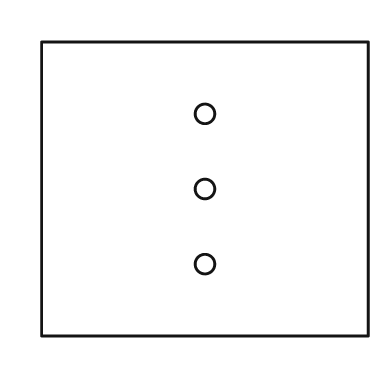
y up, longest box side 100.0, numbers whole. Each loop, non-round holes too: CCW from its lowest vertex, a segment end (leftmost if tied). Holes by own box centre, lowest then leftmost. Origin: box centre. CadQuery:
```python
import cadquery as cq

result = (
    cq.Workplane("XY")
    .moveTo(-50.0, -45.0)
    .lineTo(50.0, -45.0)
    .lineTo(50.0, 45.0)
    .lineTo(-50.0, 45.0)
    .close()
    .moveTo(0.0, -23.0)
    .circle(3.0)
    .moveTo(0.0, 0.0)
    .circle(3.0)
    .moveTo(0.0, 23.0)
    .circle(3.0)
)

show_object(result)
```